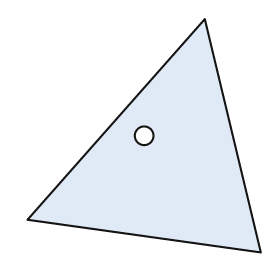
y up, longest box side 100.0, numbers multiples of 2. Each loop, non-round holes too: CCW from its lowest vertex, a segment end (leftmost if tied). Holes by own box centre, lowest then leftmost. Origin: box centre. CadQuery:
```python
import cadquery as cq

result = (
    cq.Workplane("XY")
    .moveTo(50.0, -50.0)
    .lineTo(26.0, 50.0)
    .lineTo(-50.0, -36.0)
    .close()
    .moveTo(0.0, 0.0)
    .circle(4.0)
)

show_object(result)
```